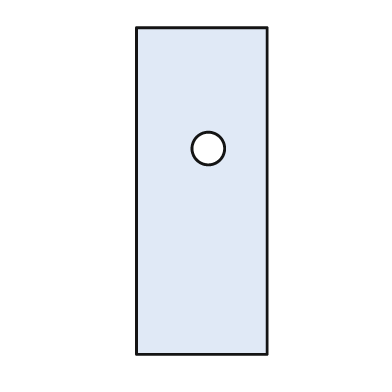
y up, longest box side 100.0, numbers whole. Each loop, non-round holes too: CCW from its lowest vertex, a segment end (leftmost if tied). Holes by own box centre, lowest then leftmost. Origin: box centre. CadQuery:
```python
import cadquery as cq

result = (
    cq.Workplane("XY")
    .moveTo(-20.0, -50.0)
    .lineTo(20.0, -50.0)
    .lineTo(20.0, 50.0)
    .lineTo(-20.0, 50.0)
    .close()
    .moveTo(2.0, 13.0)
    .circle(5.0)
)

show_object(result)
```